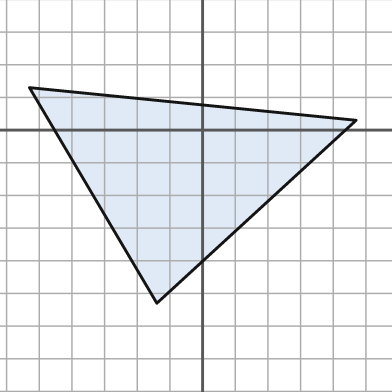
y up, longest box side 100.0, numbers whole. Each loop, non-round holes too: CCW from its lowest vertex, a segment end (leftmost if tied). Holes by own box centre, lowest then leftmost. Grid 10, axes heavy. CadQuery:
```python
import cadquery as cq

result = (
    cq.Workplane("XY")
    .moveTo(-14.0, -53.0)
    .lineTo(47.0, 3.0)
    .lineTo(-53.0, 13.0)
    .close()
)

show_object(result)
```